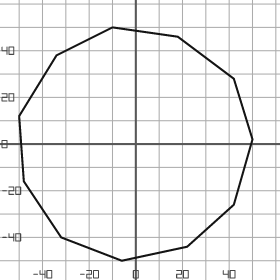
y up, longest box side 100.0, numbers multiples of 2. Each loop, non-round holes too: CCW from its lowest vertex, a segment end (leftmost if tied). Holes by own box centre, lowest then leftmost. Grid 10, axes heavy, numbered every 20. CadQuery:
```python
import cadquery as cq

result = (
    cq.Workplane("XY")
    .moveTo(-6.0, -50.0)
    .lineTo(22.0, -44.0)
    .lineTo(42.0, -26.0)
    .lineTo(50.0, 2.0)
    .lineTo(42.0, 28.0)
    .lineTo(18.0, 46.0)
    .lineTo(-10.0, 50.0)
    .lineTo(-34.0, 38.0)
    .lineTo(-50.0, 12.0)
    .lineTo(-48.0, -16.0)
    .lineTo(-32.0, -40.0)
    .close()
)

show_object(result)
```